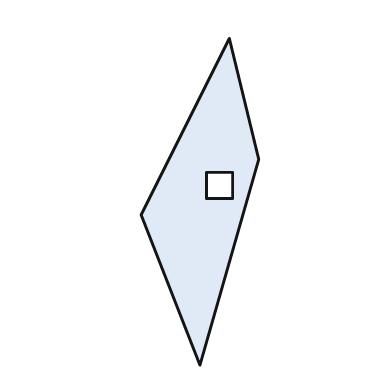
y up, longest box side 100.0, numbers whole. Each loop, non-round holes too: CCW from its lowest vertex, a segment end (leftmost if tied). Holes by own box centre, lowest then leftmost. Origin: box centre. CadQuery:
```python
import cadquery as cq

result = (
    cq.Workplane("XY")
    .moveTo(0.0, -50.0)
    .lineTo(18.0, 13.0)
    .lineTo(9.0, 50.0)
    .lineTo(-18.0, -4.0)
    .close()
    .moveTo(2.0, 1.0)
    .lineTo(10.0, 1.0)
    .lineTo(10.0, 9.0)
    .lineTo(2.0, 9.0)
    .close()
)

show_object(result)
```